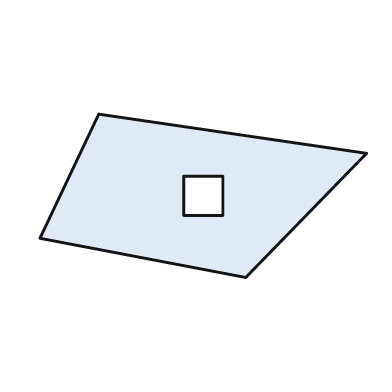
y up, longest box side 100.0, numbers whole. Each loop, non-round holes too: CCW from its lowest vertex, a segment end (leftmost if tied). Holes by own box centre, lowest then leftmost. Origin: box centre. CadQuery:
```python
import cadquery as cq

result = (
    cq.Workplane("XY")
    .moveTo(13.0, -25.0)
    .lineTo(50.0, 13.0)
    .lineTo(-32.0, 25.0)
    .lineTo(-50.0, -13.0)
    .close()
    .moveTo(-6.0, -6.0)
    .lineTo(6.0, -6.0)
    .lineTo(6.0, 6.0)
    .lineTo(-6.0, 6.0)
    .close()
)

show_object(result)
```